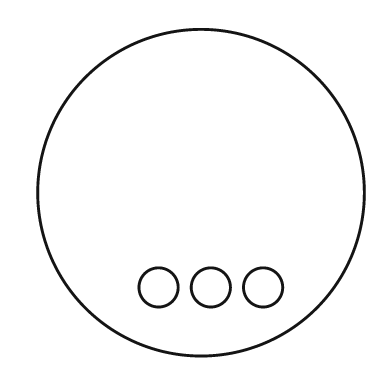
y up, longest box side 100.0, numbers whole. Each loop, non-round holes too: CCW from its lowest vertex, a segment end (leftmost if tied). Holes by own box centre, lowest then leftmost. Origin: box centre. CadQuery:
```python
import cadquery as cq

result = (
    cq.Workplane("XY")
    .moveTo(0.0, 0.0)
    .circle(50.0)
    .moveTo(-13.0, -29.0)
    .circle(6.0)
    .moveTo(3.0, -29.0)
    .circle(6.0)
    .moveTo(19.0, -29.0)
    .circle(6.0)
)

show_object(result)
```